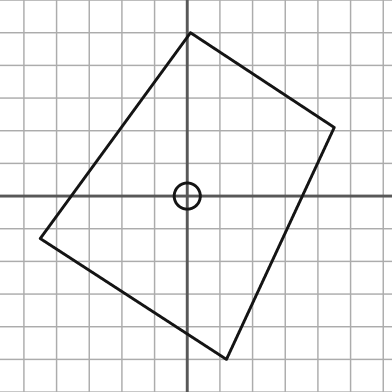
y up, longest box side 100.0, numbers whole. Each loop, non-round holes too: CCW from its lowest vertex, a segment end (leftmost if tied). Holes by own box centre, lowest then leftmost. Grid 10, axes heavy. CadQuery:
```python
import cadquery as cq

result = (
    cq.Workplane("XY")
    .moveTo(12.0, -50.0)
    .lineTo(45.0, 21.0)
    .lineTo(1.0, 50.0)
    .lineTo(-45.0, -13.0)
    .close()
    .moveTo(0.0, 0.0)
    .circle(4.0)
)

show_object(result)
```